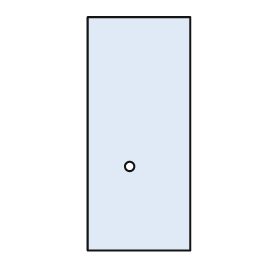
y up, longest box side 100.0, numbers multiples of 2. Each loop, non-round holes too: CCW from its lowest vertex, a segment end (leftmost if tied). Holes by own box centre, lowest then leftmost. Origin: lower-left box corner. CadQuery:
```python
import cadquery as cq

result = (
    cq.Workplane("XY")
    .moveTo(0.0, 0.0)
    .lineTo(44.0, 0.0)
    .lineTo(44.0, 100.0)
    .lineTo(0.0, 100.0)
    .close()
    .moveTo(18.0, 36.0)
    .circle(2.0)
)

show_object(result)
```